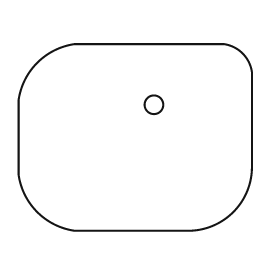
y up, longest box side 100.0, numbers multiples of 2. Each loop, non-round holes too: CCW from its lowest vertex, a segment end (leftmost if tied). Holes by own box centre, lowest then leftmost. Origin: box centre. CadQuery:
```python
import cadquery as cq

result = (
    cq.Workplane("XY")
    .moveTo(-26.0, -40.0)
    .lineTo(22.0, -40.0)
    .threePointArc((42.0, -32.0), (50.0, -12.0))
    .lineTo(50.0, 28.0)
    .threePointArc((46.0, 36.0), (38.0, 40.0))
    .lineTo(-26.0, 40.0)
    .threePointArc((-42.0, 32.0), (-50.0, 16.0))
    .lineTo(-50.0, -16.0)
    .threePointArc((-42.0, -32.0), (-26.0, -40.0))
    .close()
    .moveTo(8.0, 14.0)
    .circle(4.0)
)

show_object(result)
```